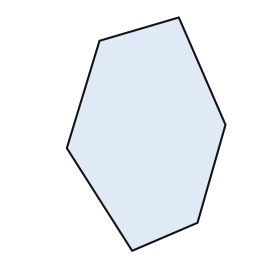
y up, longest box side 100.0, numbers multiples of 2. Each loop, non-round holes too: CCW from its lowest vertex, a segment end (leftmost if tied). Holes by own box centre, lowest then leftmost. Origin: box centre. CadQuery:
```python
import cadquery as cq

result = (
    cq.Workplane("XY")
    .moveTo(-6.0, -50.0)
    .lineTo(22.0, -38.0)
    .lineTo(34.0, 4.0)
    .lineTo(14.0, 50.0)
    .lineTo(-20.0, 40.0)
    .lineTo(-34.0, -6.0)
    .close()
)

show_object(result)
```